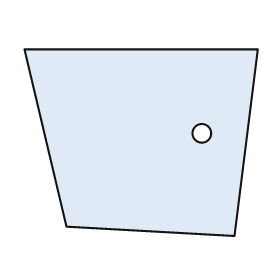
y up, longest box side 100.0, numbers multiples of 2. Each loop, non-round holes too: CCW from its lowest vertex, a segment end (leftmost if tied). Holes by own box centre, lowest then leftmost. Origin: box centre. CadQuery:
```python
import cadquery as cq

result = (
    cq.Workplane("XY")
    .moveTo(40.0, -40.0)
    .lineTo(50.0, 40.0)
    .lineTo(-50.0, 40.0)
    .lineTo(-32.0, -36.0)
    .close()
    .moveTo(26.0, 4.0)
    .circle(4.0)
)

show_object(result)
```